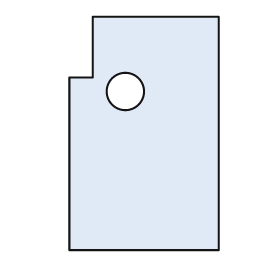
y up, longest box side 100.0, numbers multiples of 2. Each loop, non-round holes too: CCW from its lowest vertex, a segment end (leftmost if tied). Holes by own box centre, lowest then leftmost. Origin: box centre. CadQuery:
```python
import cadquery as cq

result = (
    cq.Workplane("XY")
    .moveTo(-32.0, -50.0)
    .lineTo(32.0, -50.0)
    .lineTo(32.0, 50.0)
    .lineTo(-22.0, 50.0)
    .lineTo(-22.0, 24.0)
    .lineTo(-32.0, 24.0)
    .close()
    .moveTo(-8.0, 18.0)
    .circle(8.0)
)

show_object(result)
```